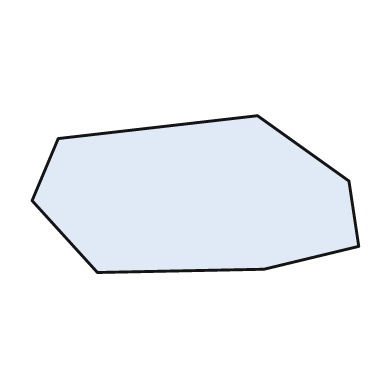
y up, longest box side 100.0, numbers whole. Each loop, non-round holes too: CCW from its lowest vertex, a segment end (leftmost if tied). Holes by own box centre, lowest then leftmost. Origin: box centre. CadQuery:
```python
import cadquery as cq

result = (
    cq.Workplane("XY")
    .moveTo(-30.0, -24.0)
    .lineTo(21.0, -23.0)
    .lineTo(50.0, -16.0)
    .lineTo(47.0, 4.0)
    .lineTo(19.0, 24.0)
    .lineTo(-42.0, 17.0)
    .lineTo(-50.0, -2.0)
    .close()
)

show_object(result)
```